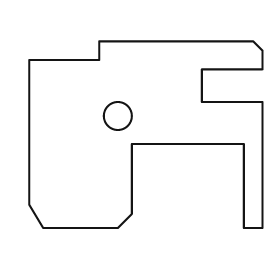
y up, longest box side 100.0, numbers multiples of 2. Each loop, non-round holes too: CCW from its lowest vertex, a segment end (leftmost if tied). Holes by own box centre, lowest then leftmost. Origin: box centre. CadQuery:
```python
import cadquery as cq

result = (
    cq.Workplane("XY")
    .moveTo(-44.0, -40.0)
    .lineTo(-12.0, -40.0)
    .lineTo(-6.0, -34.0)
    .lineTo(-6.0, -4.0)
    .lineTo(42.0, -4.0)
    .lineTo(42.0, -40.0)
    .lineTo(50.0, -40.0)
    .lineTo(50.0, 14.0)
    .lineTo(24.0, 14.0)
    .lineTo(24.0, 28.0)
    .lineTo(50.0, 28.0)
    .lineTo(50.0, 36.0)
    .lineTo(46.0, 40.0)
    .lineTo(-20.0, 40.0)
    .lineTo(-20.0, 32.0)
    .lineTo(-50.0, 32.0)
    .lineTo(-50.0, -30.0)
    .close()
    .moveTo(-12.0, 8.0)
    .circle(6.0)
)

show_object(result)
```